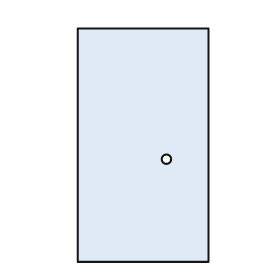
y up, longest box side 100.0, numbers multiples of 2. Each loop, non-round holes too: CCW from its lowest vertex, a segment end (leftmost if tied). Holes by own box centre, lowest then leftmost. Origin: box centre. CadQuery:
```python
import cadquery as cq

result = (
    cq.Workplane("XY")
    .moveTo(-28.0, -50.0)
    .lineTo(28.0, -50.0)
    .lineTo(28.0, 50.0)
    .lineTo(-28.0, 50.0)
    .close()
    .moveTo(10.0, -6.0)
    .circle(2.0)
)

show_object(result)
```